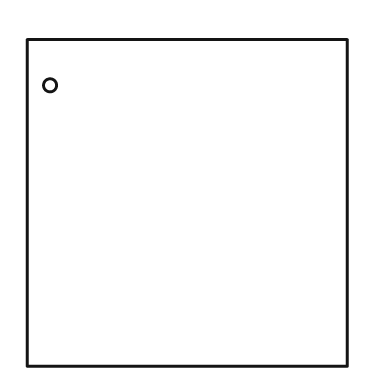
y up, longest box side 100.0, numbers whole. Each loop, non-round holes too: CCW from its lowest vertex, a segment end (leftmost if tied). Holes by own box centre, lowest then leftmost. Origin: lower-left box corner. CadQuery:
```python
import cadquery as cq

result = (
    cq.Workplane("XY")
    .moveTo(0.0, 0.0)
    .lineTo(98.0, 0.0)
    .lineTo(98.0, 100.0)
    .lineTo(0.0, 100.0)
    .close()
    .moveTo(7.0, 86.0)
    .circle(2.0)
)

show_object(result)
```